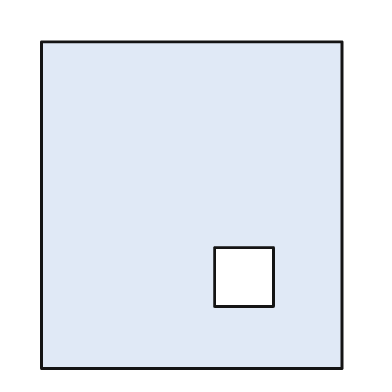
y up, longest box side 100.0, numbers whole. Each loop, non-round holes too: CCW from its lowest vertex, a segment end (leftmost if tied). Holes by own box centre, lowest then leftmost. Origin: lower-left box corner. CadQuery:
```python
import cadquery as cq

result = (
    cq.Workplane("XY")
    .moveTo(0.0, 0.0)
    .lineTo(92.0, 0.0)
    .lineTo(92.0, 100.0)
    .lineTo(0.0, 100.0)
    .close()
    .moveTo(53.0, 19.0)
    .lineTo(71.0, 19.0)
    .lineTo(71.0, 37.0)
    .lineTo(53.0, 37.0)
    .close()
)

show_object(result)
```